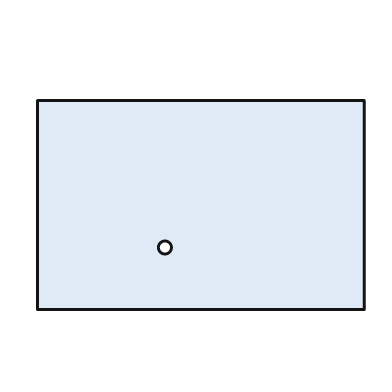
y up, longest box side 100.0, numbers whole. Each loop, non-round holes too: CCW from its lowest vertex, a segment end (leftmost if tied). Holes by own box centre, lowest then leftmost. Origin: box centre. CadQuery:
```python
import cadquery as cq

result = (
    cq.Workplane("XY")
    .moveTo(-50.0, -32.0)
    .lineTo(50.0, -32.0)
    .lineTo(50.0, 32.0)
    .lineTo(-50.0, 32.0)
    .close()
    .moveTo(-11.0, -13.0)
    .circle(2.0)
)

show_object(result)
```